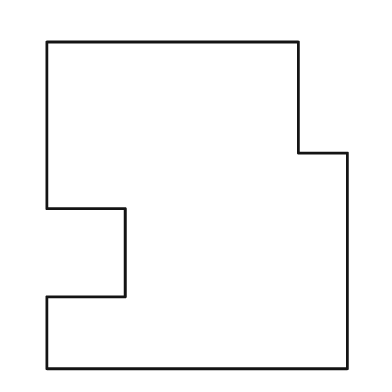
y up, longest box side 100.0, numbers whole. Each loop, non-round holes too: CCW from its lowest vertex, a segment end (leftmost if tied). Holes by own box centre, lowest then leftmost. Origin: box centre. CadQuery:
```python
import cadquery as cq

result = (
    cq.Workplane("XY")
    .moveTo(-46.0, -50.0)
    .lineTo(46.0, -50.0)
    .lineTo(46.0, 16.0)
    .lineTo(31.0, 16.0)
    .lineTo(31.0, 50.0)
    .lineTo(-46.0, 50.0)
    .lineTo(-46.0, -1.0)
    .lineTo(-22.0, -1.0)
    .lineTo(-22.0, -28.0)
    .lineTo(-46.0, -28.0)
    .close()
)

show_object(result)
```